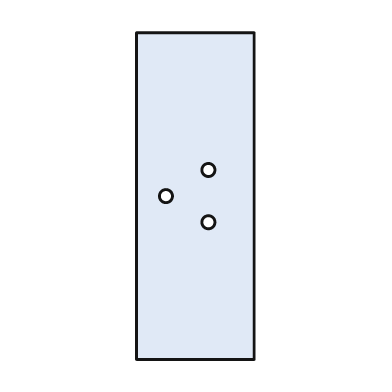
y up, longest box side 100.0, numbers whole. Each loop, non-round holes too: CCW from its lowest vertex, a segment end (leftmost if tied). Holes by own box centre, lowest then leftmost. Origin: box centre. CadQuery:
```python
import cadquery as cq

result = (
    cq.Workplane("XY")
    .moveTo(-18.0, -50.0)
    .lineTo(18.0, -50.0)
    .lineTo(18.0, 50.0)
    .lineTo(-18.0, 50.0)
    .close()
    .moveTo(4.0, -8.0)
    .circle(2.0)
    .moveTo(-9.0, 0.0)
    .circle(2.0)
    .moveTo(4.0, 8.0)
    .circle(2.0)
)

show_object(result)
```